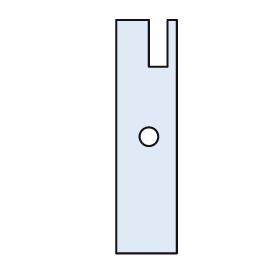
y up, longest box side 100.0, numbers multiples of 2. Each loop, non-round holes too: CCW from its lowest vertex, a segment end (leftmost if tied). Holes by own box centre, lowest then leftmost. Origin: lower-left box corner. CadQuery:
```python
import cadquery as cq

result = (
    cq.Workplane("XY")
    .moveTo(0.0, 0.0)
    .lineTo(26.0, 0.0)
    .lineTo(26.0, 100.0)
    .lineTo(22.0, 100.0)
    .lineTo(22.0, 80.0)
    .lineTo(14.0, 80.0)
    .lineTo(14.0, 100.0)
    .lineTo(0.0, 100.0)
    .close()
    .moveTo(14.0, 50.0)
    .circle(4.0)
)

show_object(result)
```